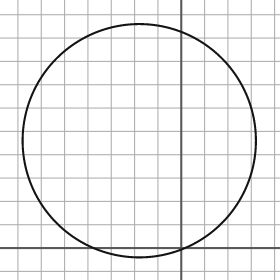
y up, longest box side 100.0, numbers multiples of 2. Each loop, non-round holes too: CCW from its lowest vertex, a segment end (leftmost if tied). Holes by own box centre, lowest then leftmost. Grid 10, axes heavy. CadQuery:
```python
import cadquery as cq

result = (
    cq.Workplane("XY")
    .moveTo(-18.0, 46.0)
    .circle(50.0)
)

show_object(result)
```